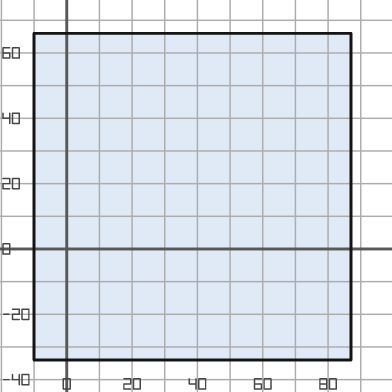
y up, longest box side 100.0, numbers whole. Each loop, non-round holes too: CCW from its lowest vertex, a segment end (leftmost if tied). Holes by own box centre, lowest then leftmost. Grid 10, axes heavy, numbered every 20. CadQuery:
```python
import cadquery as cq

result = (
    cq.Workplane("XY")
    .moveTo(-10.0, -34.0)
    .lineTo(87.0, -34.0)
    .lineTo(87.0, 66.0)
    .lineTo(-10.0, 66.0)
    .close()
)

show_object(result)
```